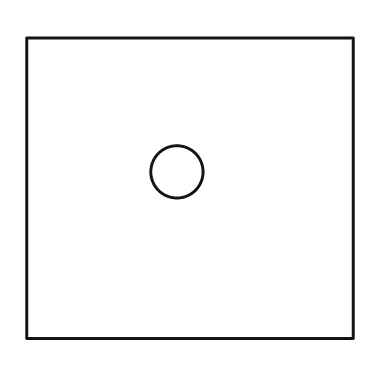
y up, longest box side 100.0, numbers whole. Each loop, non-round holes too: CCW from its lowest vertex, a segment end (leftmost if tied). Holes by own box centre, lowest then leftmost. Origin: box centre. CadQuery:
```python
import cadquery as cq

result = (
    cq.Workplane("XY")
    .moveTo(-50.0, -46.0)
    .lineTo(50.0, -46.0)
    .lineTo(50.0, 46.0)
    .lineTo(-50.0, 46.0)
    .close()
    .moveTo(-4.0, 5.0)
    .circle(8.0)
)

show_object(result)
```